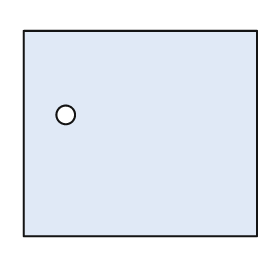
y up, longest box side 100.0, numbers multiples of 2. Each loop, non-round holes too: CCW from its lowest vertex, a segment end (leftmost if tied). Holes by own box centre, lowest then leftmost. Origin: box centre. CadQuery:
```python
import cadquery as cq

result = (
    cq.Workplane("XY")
    .moveTo(-50.0, -44.0)
    .lineTo(50.0, -44.0)
    .lineTo(50.0, 44.0)
    .lineTo(-50.0, 44.0)
    .close()
    .moveTo(-32.0, 8.0)
    .circle(4.0)
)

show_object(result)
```